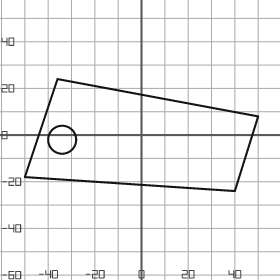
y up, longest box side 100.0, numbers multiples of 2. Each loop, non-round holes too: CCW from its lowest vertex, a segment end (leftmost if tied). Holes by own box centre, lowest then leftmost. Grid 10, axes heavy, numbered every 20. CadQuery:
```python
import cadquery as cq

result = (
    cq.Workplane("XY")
    .moveTo(40.0, -24.0)
    .lineTo(50.0, 8.0)
    .lineTo(-36.0, 24.0)
    .lineTo(-50.0, -18.0)
    .close()
    .moveTo(-34.0, -2.0)
    .circle(6.0)
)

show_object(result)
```